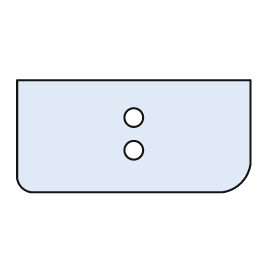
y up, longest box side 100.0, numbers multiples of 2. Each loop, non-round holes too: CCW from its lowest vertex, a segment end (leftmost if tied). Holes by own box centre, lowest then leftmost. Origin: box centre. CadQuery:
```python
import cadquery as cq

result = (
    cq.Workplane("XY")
    .moveTo(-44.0, -24.0)
    .lineTo(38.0, -24.0)
    .threePointArc((46.0, -20.0), (50.0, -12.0))
    .lineTo(50.0, 24.0)
    .lineTo(-50.0, 24.0)
    .lineTo(-50.0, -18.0)
    .threePointArc((-48.0, -22.0), (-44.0, -24.0))
    .close()
    .moveTo(0.0, -6.0)
    .circle(4.0)
    .moveTo(0.0, 8.0)
    .circle(4.0)
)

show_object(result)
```